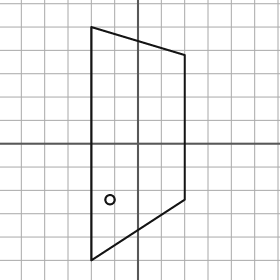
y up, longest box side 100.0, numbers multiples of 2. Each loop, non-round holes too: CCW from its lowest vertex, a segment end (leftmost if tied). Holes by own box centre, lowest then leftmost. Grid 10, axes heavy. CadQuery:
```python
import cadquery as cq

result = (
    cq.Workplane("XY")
    .moveTo(-20.0, -50.0)
    .lineTo(20.0, -24.0)
    .lineTo(20.0, 38.0)
    .lineTo(-20.0, 50.0)
    .close()
    .moveTo(-12.0, -24.0)
    .circle(2.0)
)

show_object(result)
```